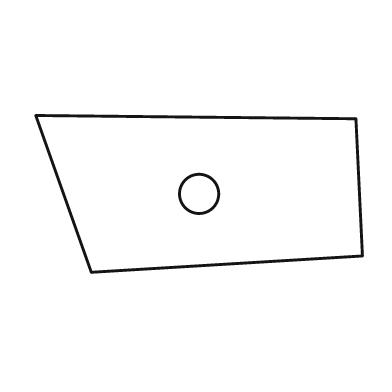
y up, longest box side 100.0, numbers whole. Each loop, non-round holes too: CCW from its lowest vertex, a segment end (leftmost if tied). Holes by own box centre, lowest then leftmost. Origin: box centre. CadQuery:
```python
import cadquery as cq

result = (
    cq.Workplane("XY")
    .moveTo(-33.0, -24.0)
    .lineTo(50.0, -19.0)
    .lineTo(48.0, 23.0)
    .lineTo(-50.0, 24.0)
    .close()
    .moveTo(0.0, 0.0)
    .circle(6.0)
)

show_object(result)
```